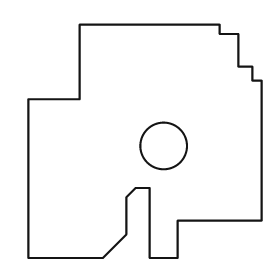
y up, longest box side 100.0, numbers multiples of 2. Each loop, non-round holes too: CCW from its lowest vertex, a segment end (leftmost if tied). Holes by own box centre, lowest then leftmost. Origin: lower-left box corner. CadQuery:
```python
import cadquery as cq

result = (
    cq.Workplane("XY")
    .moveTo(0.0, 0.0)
    .lineTo(32.0, 0.0)
    .lineTo(42.0, 10.0)
    .lineTo(42.0, 26.0)
    .lineTo(46.0, 30.0)
    .lineTo(52.0, 30.0)
    .lineTo(52.0, 0.0)
    .lineTo(64.0, 0.0)
    .lineTo(64.0, 16.0)
    .lineTo(100.0, 16.0)
    .lineTo(100.0, 76.0)
    .lineTo(96.0, 76.0)
    .lineTo(96.0, 82.0)
    .lineTo(90.0, 82.0)
    .lineTo(90.0, 96.0)
    .lineTo(82.0, 96.0)
    .lineTo(82.0, 100.0)
    .lineTo(22.0, 100.0)
    .lineTo(22.0, 68.0)
    .lineTo(0.0, 68.0)
    .close()
    .moveTo(58.0, 48.0)
    .circle(10.0)
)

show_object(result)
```